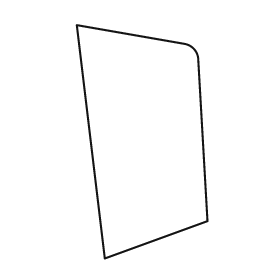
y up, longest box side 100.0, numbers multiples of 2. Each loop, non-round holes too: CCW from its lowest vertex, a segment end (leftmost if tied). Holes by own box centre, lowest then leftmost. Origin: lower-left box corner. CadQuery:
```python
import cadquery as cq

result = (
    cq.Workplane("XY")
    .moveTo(12.0, 0.0)
    .lineTo(56.0, 16.0)
    .lineTo(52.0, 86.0)
    .threePointArc((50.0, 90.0), (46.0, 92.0))
    .lineTo(0.0, 100.0)
    .close()
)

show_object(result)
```